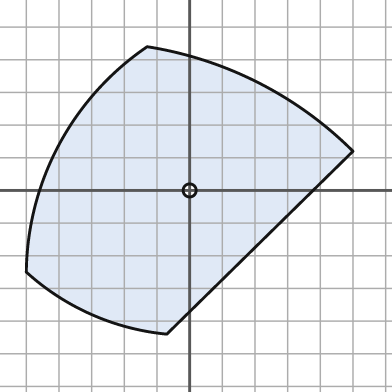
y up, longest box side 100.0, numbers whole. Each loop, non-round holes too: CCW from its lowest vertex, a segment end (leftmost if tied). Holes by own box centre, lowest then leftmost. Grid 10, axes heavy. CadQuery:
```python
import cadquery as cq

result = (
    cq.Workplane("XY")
    .moveTo(-7.0, -44.0)
    .lineTo(50.0, 12.0)
    .threePointArc((21.0, 33.0), (-13.0, 44.0))
    .threePointArc((-40.0, 14.0), (-50.0, -25.0))
    .threePointArc((-30.0, -38.0), (-7.0, -44.0))
    .close()
    .moveTo(0.0, 0.0)
    .circle(2.0)
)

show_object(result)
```